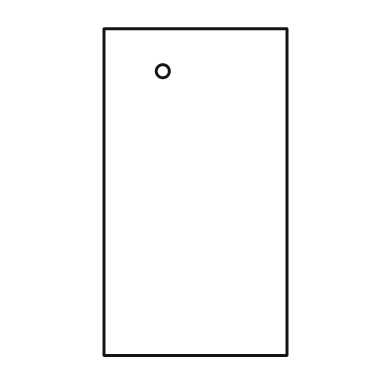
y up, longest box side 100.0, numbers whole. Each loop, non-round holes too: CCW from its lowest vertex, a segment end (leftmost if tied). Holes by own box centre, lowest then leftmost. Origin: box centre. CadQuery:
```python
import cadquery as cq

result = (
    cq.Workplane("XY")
    .moveTo(-28.0, -50.0)
    .lineTo(28.0, -50.0)
    .lineTo(28.0, 50.0)
    .lineTo(-28.0, 50.0)
    .close()
    .moveTo(-10.0, 37.0)
    .circle(2.0)
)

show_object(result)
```